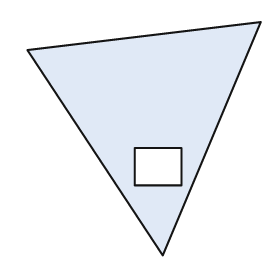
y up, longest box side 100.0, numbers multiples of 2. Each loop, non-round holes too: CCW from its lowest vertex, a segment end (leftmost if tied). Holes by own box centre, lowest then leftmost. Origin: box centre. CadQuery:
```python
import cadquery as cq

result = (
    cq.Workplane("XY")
    .moveTo(8.0, -50.0)
    .lineTo(50.0, 50.0)
    .lineTo(-50.0, 38.0)
    .close()
    .moveTo(-4.0, -20.0)
    .lineTo(16.0, -20.0)
    .lineTo(16.0, -4.0)
    .lineTo(-4.0, -4.0)
    .close()
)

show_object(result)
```